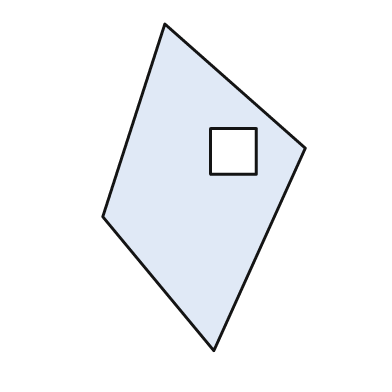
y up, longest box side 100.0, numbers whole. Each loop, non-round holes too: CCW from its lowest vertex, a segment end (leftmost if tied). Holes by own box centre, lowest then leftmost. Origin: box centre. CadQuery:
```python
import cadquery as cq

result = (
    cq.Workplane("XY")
    .moveTo(3.0, -50.0)
    .lineTo(31.0, 12.0)
    .lineTo(-12.0, 50.0)
    .lineTo(-31.0, -9.0)
    .close()
    .moveTo(2.0, 4.0)
    .lineTo(16.0, 4.0)
    .lineTo(16.0, 18.0)
    .lineTo(2.0, 18.0)
    .close()
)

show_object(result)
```